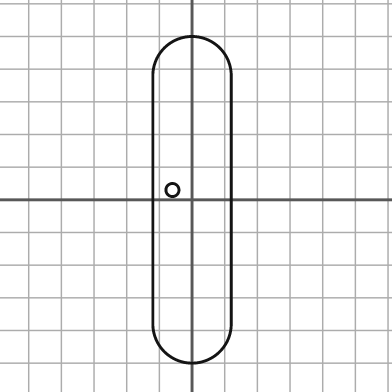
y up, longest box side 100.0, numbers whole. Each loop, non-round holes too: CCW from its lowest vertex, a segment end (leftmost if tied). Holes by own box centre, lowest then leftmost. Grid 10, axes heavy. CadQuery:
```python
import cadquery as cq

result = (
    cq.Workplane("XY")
    .moveTo(-12.0, -38.0)
    .threePointArc((0.0, -50.0), (12.0, -38.0))
    .lineTo(12.0, 38.0)
    .threePointArc((0.0, 50.0), (-12.0, 38.0))
    .close()
    .moveTo(-6.0, 3.0)
    .circle(2.0)
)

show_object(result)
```